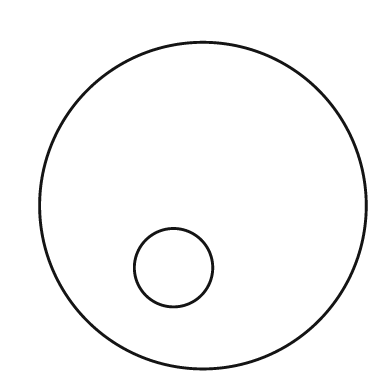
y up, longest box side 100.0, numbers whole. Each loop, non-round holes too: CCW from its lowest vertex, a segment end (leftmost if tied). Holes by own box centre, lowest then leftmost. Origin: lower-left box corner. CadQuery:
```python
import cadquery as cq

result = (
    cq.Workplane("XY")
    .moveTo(50.0, 50.0)
    .circle(50.0)
    .moveTo(41.0, 31.0)
    .circle(12.0)
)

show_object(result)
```